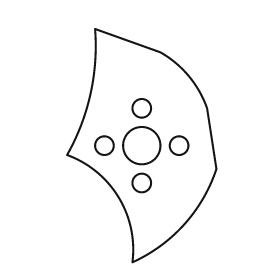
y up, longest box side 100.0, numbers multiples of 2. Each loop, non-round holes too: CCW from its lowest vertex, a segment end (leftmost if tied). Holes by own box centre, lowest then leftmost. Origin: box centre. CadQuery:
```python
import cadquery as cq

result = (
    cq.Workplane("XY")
    .moveTo(-4.0, -50.0)
    .threePointArc((18.0, -34.0), (32.0, -10.0))
    .lineTo(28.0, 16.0)
    .threePointArc((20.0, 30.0), (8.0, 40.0))
    .lineTo(-20.0, 50.0)
    .threePointArc((-22.0, 22.0), (-32.0, -4.0))
    .threePointArc((-10.0, -22.0), (-4.0, -50.0))
    .close()
    .moveTo(0.0, -16.0)
    .circle(4.0)
    .moveTo(-16.0, 0.0)
    .circle(4.0)
    .moveTo(0.0, 0.0)
    .circle(8.0)
    .moveTo(16.0, 0.0)
    .circle(4.0)
    .moveTo(0.0, 16.0)
    .circle(4.0)
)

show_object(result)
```